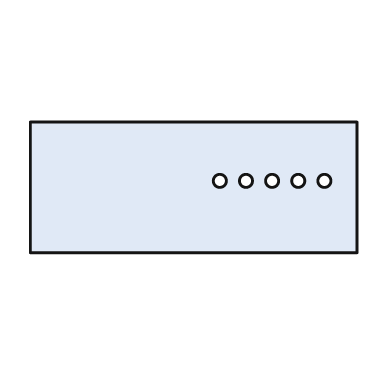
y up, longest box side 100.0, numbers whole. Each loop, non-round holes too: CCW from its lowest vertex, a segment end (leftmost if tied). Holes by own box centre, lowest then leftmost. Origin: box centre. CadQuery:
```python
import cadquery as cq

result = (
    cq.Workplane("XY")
    .moveTo(-50.0, -20.0)
    .lineTo(50.0, -20.0)
    .lineTo(50.0, 20.0)
    .lineTo(-50.0, 20.0)
    .close()
    .moveTo(8.0, 2.0)
    .circle(2.0)
    .moveTo(16.0, 2.0)
    .circle(2.0)
    .moveTo(24.0, 2.0)
    .circle(2.0)
    .moveTo(32.0, 2.0)
    .circle(2.0)
    .moveTo(40.0, 2.0)
    .circle(2.0)
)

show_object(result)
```